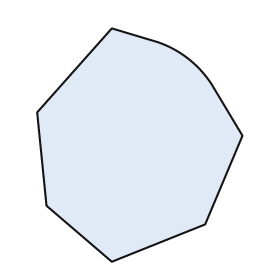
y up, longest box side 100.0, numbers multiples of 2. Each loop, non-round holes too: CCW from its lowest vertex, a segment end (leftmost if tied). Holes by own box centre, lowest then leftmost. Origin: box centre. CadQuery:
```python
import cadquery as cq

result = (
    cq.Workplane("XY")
    .moveTo(-12.0, -50.0)
    .lineTo(28.0, -34.0)
    .lineTo(44.0, 4.0)
    .lineTo(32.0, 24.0)
    .threePointArc((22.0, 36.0), (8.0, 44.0))
    .lineTo(-12.0, 50.0)
    .lineTo(-44.0, 14.0)
    .lineTo(-40.0, -26.0)
    .close()
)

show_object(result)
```